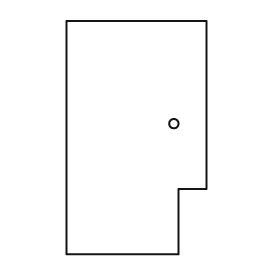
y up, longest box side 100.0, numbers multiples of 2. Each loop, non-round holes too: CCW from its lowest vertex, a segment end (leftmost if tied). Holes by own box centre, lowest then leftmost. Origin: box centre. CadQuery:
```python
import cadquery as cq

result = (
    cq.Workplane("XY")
    .moveTo(-30.0, -50.0)
    .lineTo(18.0, -50.0)
    .lineTo(18.0, -22.0)
    .lineTo(30.0, -22.0)
    .lineTo(30.0, 50.0)
    .lineTo(-30.0, 50.0)
    .close()
    .moveTo(16.0, 6.0)
    .circle(2.0)
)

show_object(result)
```